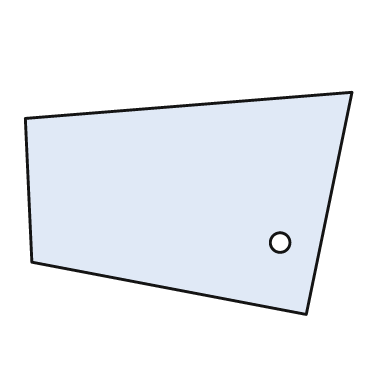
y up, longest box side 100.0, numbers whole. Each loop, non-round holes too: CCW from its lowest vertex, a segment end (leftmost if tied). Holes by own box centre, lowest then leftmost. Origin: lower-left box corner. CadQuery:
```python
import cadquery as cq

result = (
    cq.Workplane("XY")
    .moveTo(86.0, 0.0)
    .lineTo(100.0, 68.0)
    .lineTo(0.0, 60.0)
    .lineTo(2.0, 16.0)
    .close()
    .moveTo(78.0, 22.0)
    .circle(3.0)
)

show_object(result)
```